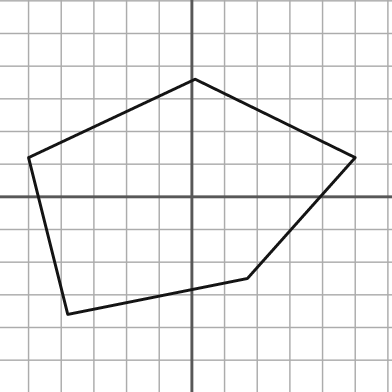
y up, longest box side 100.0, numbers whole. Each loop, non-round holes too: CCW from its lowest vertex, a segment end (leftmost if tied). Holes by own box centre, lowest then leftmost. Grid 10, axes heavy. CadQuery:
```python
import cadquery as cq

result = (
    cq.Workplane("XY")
    .moveTo(-38.0, -36.0)
    .lineTo(17.0, -25.0)
    .lineTo(50.0, 12.0)
    .lineTo(1.0, 36.0)
    .lineTo(-50.0, 12.0)
    .close()
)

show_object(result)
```